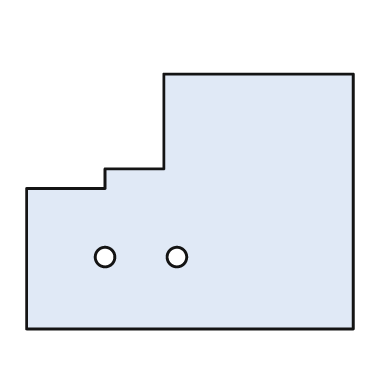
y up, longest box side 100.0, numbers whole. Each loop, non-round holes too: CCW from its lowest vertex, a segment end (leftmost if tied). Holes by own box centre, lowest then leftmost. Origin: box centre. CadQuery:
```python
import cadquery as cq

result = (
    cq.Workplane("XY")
    .moveTo(-50.0, -39.0)
    .lineTo(50.0, -39.0)
    .lineTo(50.0, 39.0)
    .lineTo(-8.0, 39.0)
    .lineTo(-8.0, 10.0)
    .lineTo(-26.0, 10.0)
    .lineTo(-26.0, 4.0)
    .lineTo(-50.0, 4.0)
    .close()
    .moveTo(-26.0, -17.0)
    .circle(3.0)
    .moveTo(-4.0, -17.0)
    .circle(3.0)
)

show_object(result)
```